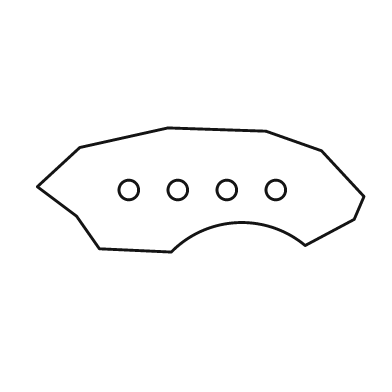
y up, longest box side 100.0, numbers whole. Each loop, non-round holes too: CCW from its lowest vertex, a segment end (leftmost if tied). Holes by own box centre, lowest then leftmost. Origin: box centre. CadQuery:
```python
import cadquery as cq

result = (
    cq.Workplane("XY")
    .moveTo(-9.0, -19.0)
    .threePointArc((11.0, -10.0), (32.0, -17.0))
    .lineTo(47.0, -9.0)
    .lineTo(50.0, -2.0)
    .lineTo(37.0, 12.0)
    .lineTo(20.0, 18.0)
    .lineTo(-10.0, 19.0)
    .lineTo(-37.0, 13.0)
    .lineTo(-50.0, 1.0)
    .lineTo(-38.0, -8.0)
    .lineTo(-31.0, -18.0)
    .close()
    .moveTo(-22.0, 0.0)
    .circle(3.0)
    .moveTo(-7.0, 0.0)
    .circle(3.0)
    .moveTo(8.0, 0.0)
    .circle(3.0)
    .moveTo(23.0, 0.0)
    .circle(3.0)
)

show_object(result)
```